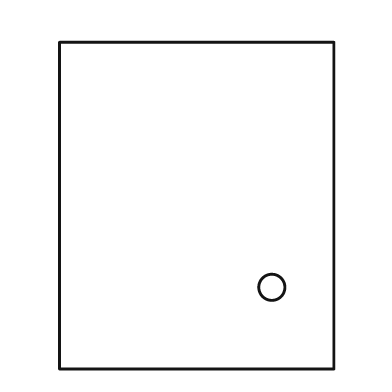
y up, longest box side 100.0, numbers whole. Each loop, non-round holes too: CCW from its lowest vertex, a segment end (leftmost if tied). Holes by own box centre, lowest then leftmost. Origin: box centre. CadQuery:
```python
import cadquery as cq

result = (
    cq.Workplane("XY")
    .moveTo(-42.0, -50.0)
    .lineTo(42.0, -50.0)
    .lineTo(42.0, 50.0)
    .lineTo(-42.0, 50.0)
    .close()
    .moveTo(23.0, -25.0)
    .circle(4.0)
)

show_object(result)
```